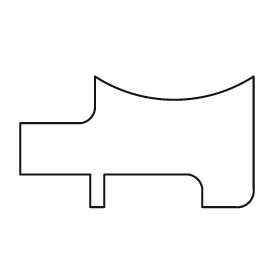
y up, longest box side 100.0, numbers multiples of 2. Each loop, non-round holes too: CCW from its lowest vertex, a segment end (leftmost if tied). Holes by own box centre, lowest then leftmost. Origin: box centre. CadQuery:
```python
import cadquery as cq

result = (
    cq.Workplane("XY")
    .moveTo(-20.0, -28.0)
    .lineTo(-14.0, -28.0)
    .lineTo(-14.0, -14.0)
    .lineTo(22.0, -14.0)
    .threePointArc((26.0, -16.0), (28.0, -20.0))
    .lineTo(28.0, -28.0)
    .lineTo(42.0, -28.0)
    .threePointArc((48.0, -26.0), (50.0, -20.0))
    .lineTo(50.0, 28.0)
    .threePointArc((16.0, 18.0), (-18.0, 28.0))
    .lineTo(-18.0, 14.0)
    .threePointArc((-20.0, 10.0), (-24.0, 8.0))
    .lineTo(-50.0, 8.0)
    .lineTo(-50.0, -14.0)
    .lineTo(-20.0, -14.0)
    .close()
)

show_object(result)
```